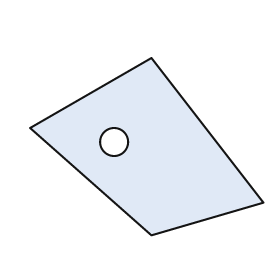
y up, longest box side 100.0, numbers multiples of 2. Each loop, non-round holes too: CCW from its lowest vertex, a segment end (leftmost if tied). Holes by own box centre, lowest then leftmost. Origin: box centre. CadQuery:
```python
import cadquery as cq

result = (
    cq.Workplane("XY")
    .moveTo(2.0, -38.0)
    .lineTo(50.0, -24.0)
    .lineTo(2.0, 38.0)
    .lineTo(-50.0, 8.0)
    .close()
    .moveTo(-14.0, 2.0)
    .circle(6.0)
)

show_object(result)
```